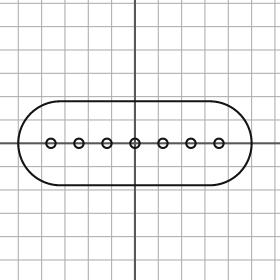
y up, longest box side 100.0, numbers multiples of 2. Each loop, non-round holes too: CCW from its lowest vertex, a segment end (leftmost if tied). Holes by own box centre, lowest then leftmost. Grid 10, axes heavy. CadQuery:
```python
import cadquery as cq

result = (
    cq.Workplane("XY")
    .moveTo(-32.0, -18.0)
    .lineTo(32.0, -18.0)
    .threePointArc((50.0, 0.0), (32.0, 18.0))
    .lineTo(-32.0, 18.0)
    .threePointArc((-50.0, 0.0), (-32.0, -18.0))
    .close()
    .moveTo(-36.0, 0.0)
    .circle(2.0)
    .moveTo(-24.0, 0.0)
    .circle(2.0)
    .moveTo(-12.0, 0.0)
    .circle(2.0)
    .moveTo(0.0, 0.0)
    .circle(2.0)
    .moveTo(12.0, 0.0)
    .circle(2.0)
    .moveTo(24.0, 0.0)
    .circle(2.0)
    .moveTo(36.0, 0.0)
    .circle(2.0)
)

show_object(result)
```